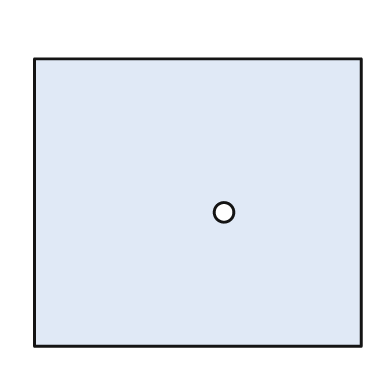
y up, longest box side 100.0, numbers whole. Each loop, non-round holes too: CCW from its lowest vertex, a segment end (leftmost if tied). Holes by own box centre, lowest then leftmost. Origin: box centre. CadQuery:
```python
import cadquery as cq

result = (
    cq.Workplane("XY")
    .moveTo(-50.0, -44.0)
    .lineTo(50.0, -44.0)
    .lineTo(50.0, 44.0)
    .lineTo(-50.0, 44.0)
    .close()
    .moveTo(8.0, -3.0)
    .circle(3.0)
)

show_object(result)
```